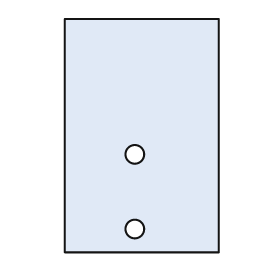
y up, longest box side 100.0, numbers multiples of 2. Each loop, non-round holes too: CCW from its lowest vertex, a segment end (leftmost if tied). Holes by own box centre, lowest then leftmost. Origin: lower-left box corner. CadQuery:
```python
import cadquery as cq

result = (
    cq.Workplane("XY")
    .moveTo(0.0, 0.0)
    .lineTo(66.0, 0.0)
    .lineTo(66.0, 100.0)
    .lineTo(0.0, 100.0)
    .close()
    .moveTo(30.0, 10.0)
    .circle(4.0)
    .moveTo(30.0, 42.0)
    .circle(4.0)
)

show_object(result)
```